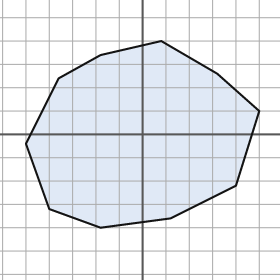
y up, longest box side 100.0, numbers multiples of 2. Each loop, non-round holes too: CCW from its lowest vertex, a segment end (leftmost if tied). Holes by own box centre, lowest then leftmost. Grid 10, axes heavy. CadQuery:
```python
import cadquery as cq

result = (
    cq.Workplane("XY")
    .moveTo(-18.0, -40.0)
    .lineTo(12.0, -36.0)
    .lineTo(40.0, -22.0)
    .lineTo(50.0, 10.0)
    .lineTo(32.0, 26.0)
    .lineTo(8.0, 40.0)
    .lineTo(-18.0, 34.0)
    .lineTo(-36.0, 24.0)
    .lineTo(-50.0, -4.0)
    .lineTo(-40.0, -32.0)
    .close()
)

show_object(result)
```